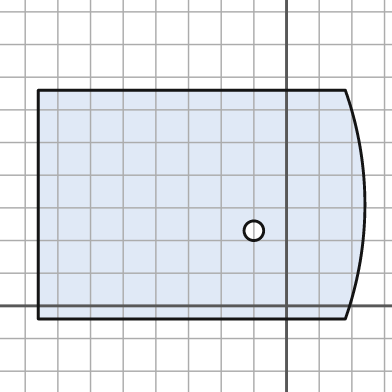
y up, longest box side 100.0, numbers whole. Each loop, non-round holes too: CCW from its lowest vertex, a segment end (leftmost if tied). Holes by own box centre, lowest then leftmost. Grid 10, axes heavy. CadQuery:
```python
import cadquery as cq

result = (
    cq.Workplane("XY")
    .moveTo(-76.0, -4.0)
    .lineTo(18.0, -4.0)
    .threePointArc((24.0, 31.0), (18.0, 66.0))
    .lineTo(-76.0, 66.0)
    .close()
    .moveTo(-10.0, 23.0)
    .circle(3.0)
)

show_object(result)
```